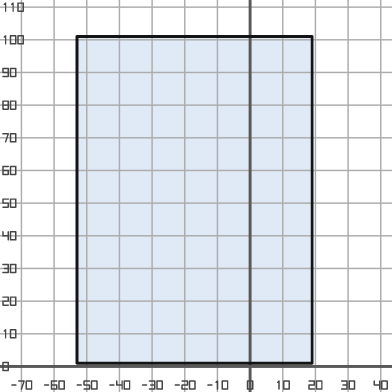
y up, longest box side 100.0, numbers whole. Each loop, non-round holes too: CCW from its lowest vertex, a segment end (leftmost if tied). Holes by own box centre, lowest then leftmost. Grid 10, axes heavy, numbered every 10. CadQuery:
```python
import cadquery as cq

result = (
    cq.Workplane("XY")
    .moveTo(-53.0, 1.0)
    .lineTo(19.0, 1.0)
    .lineTo(19.0, 101.0)
    .lineTo(-53.0, 101.0)
    .close()
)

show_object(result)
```